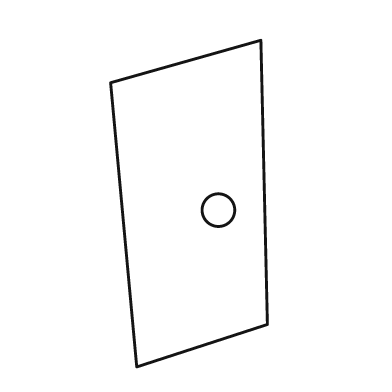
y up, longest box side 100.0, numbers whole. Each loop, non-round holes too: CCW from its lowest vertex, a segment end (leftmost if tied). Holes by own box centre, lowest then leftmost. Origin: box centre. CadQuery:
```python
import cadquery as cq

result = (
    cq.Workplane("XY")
    .moveTo(-16.0, -50.0)
    .lineTo(24.0, -37.0)
    .lineTo(22.0, 50.0)
    .lineTo(-24.0, 37.0)
    .close()
    .moveTo(9.0, -2.0)
    .circle(5.0)
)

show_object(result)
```